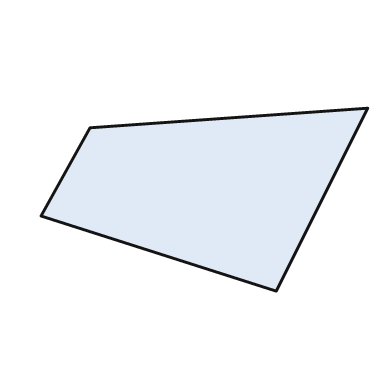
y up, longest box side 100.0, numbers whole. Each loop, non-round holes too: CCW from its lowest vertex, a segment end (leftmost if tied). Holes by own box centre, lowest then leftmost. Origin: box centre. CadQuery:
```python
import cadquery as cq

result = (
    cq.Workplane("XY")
    .moveTo(22.0, -28.0)
    .lineTo(50.0, 28.0)
    .lineTo(-35.0, 22.0)
    .lineTo(-50.0, -5.0)
    .close()
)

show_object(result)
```